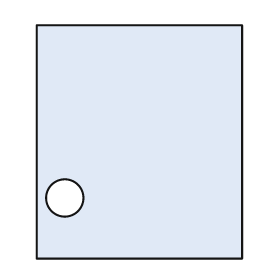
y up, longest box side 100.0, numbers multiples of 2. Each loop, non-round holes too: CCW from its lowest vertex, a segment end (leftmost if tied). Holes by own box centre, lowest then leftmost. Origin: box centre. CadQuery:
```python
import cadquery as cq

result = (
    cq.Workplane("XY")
    .moveTo(-44.0, -50.0)
    .lineTo(44.0, -50.0)
    .lineTo(44.0, 50.0)
    .lineTo(-44.0, 50.0)
    .close()
    .moveTo(-32.0, -24.0)
    .circle(8.0)
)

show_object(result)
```